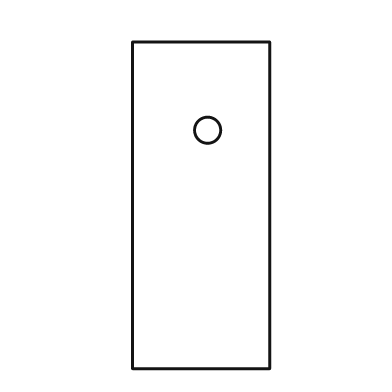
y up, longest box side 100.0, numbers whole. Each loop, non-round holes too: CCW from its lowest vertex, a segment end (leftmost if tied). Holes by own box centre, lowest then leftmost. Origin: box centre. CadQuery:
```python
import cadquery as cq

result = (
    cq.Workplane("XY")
    .moveTo(-21.0, -50.0)
    .lineTo(21.0, -50.0)
    .lineTo(21.0, 50.0)
    .lineTo(-21.0, 50.0)
    .close()
    .moveTo(2.0, 23.0)
    .circle(4.0)
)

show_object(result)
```